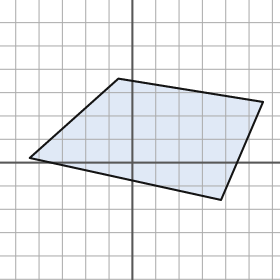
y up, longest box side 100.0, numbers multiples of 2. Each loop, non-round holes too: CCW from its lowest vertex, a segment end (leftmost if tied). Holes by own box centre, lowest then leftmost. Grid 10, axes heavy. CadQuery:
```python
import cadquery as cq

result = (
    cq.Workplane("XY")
    .moveTo(38.0, -16.0)
    .lineTo(56.0, 26.0)
    .lineTo(-6.0, 36.0)
    .lineTo(-44.0, 2.0)
    .close()
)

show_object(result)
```